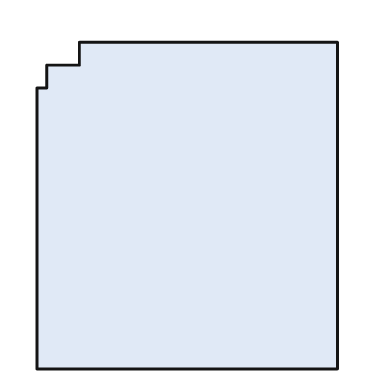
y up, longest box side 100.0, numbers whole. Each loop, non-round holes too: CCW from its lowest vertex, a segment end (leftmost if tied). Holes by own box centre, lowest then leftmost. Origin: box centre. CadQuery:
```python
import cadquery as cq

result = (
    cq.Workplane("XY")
    .moveTo(-46.0, -50.0)
    .lineTo(46.0, -50.0)
    .lineTo(46.0, 50.0)
    .lineTo(-33.0, 50.0)
    .lineTo(-33.0, 43.0)
    .lineTo(-43.0, 43.0)
    .lineTo(-43.0, 36.0)
    .lineTo(-46.0, 36.0)
    .close()
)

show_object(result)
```